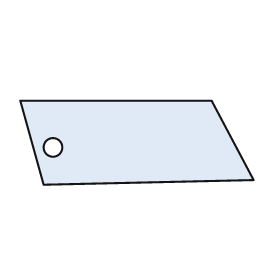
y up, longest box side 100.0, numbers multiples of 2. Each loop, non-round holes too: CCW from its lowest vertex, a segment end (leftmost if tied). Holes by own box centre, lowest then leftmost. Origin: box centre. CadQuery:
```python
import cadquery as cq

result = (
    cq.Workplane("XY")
    .moveTo(-40.0, -18.0)
    .lineTo(50.0, -16.0)
    .lineTo(32.0, 18.0)
    .lineTo(-50.0, 18.0)
    .close()
    .moveTo(-36.0, -2.0)
    .circle(4.0)
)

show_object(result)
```